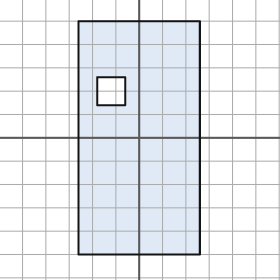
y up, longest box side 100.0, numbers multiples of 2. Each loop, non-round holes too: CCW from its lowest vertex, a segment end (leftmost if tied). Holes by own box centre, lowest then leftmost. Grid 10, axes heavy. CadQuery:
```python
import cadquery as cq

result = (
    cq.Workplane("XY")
    .moveTo(-26.0, -50.0)
    .lineTo(26.0, -50.0)
    .lineTo(26.0, 50.0)
    .lineTo(-26.0, 50.0)
    .close()
    .moveTo(-18.0, 14.0)
    .lineTo(-6.0, 14.0)
    .lineTo(-6.0, 26.0)
    .lineTo(-18.0, 26.0)
    .close()
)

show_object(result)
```